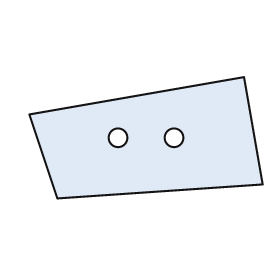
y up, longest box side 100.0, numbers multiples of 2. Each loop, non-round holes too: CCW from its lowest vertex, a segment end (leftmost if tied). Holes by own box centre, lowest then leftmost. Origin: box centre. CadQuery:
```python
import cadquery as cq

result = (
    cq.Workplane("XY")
    .moveTo(-38.0, -26.0)
    .lineTo(50.0, -20.0)
    .lineTo(42.0, 26.0)
    .lineTo(-50.0, 10.0)
    .close()
    .moveTo(-12.0, 0.0)
    .circle(4.0)
    .moveTo(12.0, 0.0)
    .circle(4.0)
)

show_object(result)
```